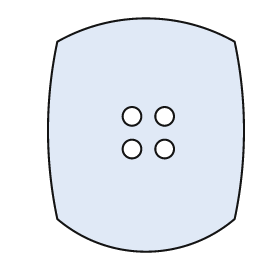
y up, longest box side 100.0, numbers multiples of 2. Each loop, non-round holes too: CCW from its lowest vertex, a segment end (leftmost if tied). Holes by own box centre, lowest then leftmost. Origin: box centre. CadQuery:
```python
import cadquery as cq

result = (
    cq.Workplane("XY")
    .moveTo(-38.0, -36.0)
    .threePointArc((0.0, -50.0), (38.0, -36.0))
    .threePointArc((42.0, 2.0), (38.0, 40.0))
    .threePointArc((0.0, 50.0), (-38.0, 40.0))
    .threePointArc((-42.0, 2.0), (-38.0, -36.0))
    .close()
    .moveTo(-6.0, -6.0)
    .circle(4.0)
    .moveTo(8.0, -6.0)
    .circle(4.0)
    .moveTo(-6.0, 8.0)
    .circle(4.0)
    .moveTo(8.0, 8.0)
    .circle(4.0)
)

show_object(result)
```